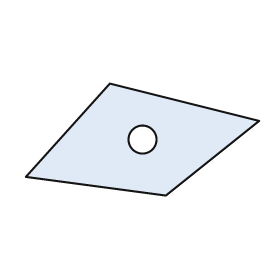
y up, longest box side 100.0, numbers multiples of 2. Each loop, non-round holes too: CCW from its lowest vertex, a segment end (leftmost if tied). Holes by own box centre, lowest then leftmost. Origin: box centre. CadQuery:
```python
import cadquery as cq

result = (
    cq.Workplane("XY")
    .moveTo(10.0, -24.0)
    .lineTo(50.0, 8.0)
    .lineTo(-14.0, 24.0)
    .lineTo(-50.0, -16.0)
    .close()
    .moveTo(0.0, 0.0)
    .circle(6.0)
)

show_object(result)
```